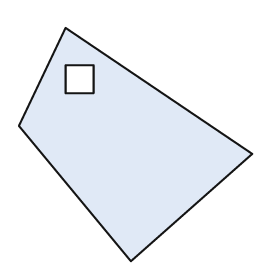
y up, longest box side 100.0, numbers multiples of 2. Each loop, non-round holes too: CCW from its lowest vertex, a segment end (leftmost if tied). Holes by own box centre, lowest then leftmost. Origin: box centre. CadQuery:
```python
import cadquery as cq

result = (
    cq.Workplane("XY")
    .moveTo(-2.0, -50.0)
    .lineTo(50.0, -4.0)
    .lineTo(-30.0, 50.0)
    .lineTo(-50.0, 8.0)
    .close()
    .moveTo(-30.0, 22.0)
    .lineTo(-18.0, 22.0)
    .lineTo(-18.0, 34.0)
    .lineTo(-30.0, 34.0)
    .close()
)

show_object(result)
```